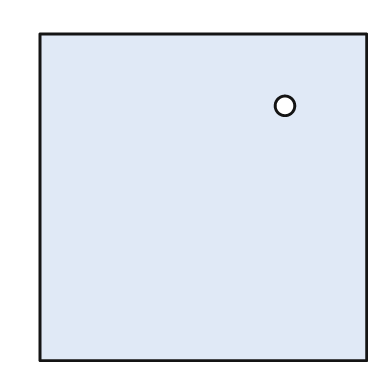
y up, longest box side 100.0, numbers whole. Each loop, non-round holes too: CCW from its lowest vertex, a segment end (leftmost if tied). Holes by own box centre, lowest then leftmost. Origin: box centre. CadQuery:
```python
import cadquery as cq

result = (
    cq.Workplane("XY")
    .moveTo(-50.0, -50.0)
    .lineTo(50.0, -50.0)
    .lineTo(50.0, 50.0)
    .lineTo(-50.0, 50.0)
    .close()
    .moveTo(25.0, 28.0)
    .circle(3.0)
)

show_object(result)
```